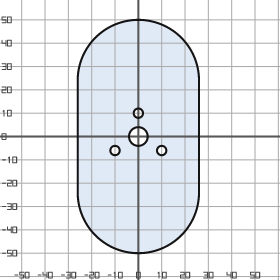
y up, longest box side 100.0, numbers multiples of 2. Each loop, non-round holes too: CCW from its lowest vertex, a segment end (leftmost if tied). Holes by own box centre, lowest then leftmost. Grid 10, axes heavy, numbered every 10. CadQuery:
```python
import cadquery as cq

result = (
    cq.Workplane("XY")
    .moveTo(-26.0, -24.0)
    .threePointArc((0.0, -50.0), (26.0, -24.0))
    .lineTo(26.0, 24.0)
    .threePointArc((0.0, 50.0), (-26.0, 24.0))
    .close()
    .moveTo(-10.0, -6.0)
    .circle(2.0)
    .moveTo(10.0, -6.0)
    .circle(2.0)
    .moveTo(0.0, 0.0)
    .circle(4.0)
    .moveTo(0.0, 10.0)
    .circle(2.0)
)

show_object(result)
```